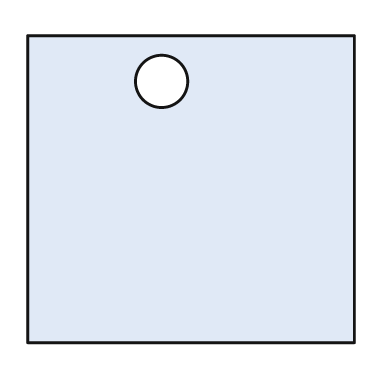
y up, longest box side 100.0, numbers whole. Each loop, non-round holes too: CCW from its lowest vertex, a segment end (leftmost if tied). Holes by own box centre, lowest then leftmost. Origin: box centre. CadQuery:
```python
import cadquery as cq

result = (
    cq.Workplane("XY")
    .moveTo(-50.0, -47.0)
    .lineTo(50.0, -47.0)
    .lineTo(50.0, 47.0)
    .lineTo(-50.0, 47.0)
    .close()
    .moveTo(-9.0, 33.0)
    .circle(8.0)
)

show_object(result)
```